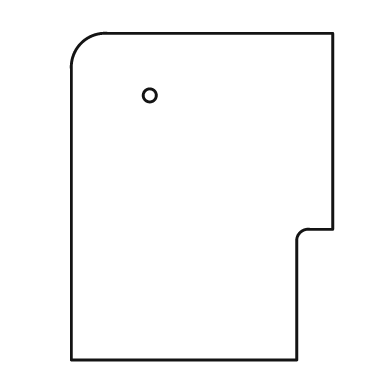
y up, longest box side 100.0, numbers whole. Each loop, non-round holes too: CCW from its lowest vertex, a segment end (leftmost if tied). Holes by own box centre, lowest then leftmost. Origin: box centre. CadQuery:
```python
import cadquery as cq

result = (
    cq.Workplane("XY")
    .moveTo(-40.0, -50.0)
    .lineTo(29.0, -50.0)
    .lineTo(29.0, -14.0)
    .threePointArc((30.0, -11.0), (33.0, -10.0))
    .lineTo(40.0, -10.0)
    .lineTo(40.0, 50.0)
    .lineTo(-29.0, 50.0)
    .threePointArc((-37.0, 47.0), (-40.0, 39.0))
    .close()
    .moveTo(-16.0, 31.0)
    .circle(2.0)
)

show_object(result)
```